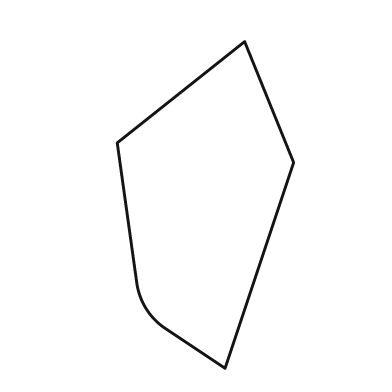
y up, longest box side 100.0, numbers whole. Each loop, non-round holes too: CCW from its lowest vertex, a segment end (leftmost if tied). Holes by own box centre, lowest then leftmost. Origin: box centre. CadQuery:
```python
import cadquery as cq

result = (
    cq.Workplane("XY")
    .moveTo(6.0, -50.0)
    .lineTo(27.0, 13.0)
    .lineTo(12.0, 50.0)
    .lineTo(-27.0, 19.0)
    .lineTo(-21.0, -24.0)
    .threePointArc((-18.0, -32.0), (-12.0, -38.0))
    .close()
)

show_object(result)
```